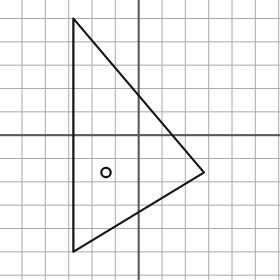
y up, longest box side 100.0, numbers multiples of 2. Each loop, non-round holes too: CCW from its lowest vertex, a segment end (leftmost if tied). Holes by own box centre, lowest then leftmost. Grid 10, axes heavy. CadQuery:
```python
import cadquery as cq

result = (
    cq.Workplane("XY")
    .moveTo(-28.0, -50.0)
    .lineTo(28.0, -16.0)
    .lineTo(-28.0, 50.0)
    .close()
    .moveTo(-14.0, -16.0)
    .circle(2.0)
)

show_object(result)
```